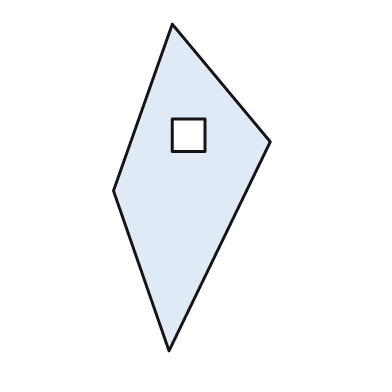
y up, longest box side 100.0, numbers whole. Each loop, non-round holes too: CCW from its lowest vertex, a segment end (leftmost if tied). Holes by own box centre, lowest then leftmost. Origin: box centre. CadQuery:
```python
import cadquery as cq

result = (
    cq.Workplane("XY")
    .moveTo(-7.0, -50.0)
    .lineTo(24.0, 14.0)
    .lineTo(-6.0, 50.0)
    .lineTo(-24.0, -1.0)
    .close()
    .moveTo(-6.0, 11.0)
    .lineTo(4.0, 11.0)
    .lineTo(4.0, 21.0)
    .lineTo(-6.0, 21.0)
    .close()
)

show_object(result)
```